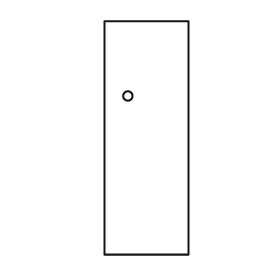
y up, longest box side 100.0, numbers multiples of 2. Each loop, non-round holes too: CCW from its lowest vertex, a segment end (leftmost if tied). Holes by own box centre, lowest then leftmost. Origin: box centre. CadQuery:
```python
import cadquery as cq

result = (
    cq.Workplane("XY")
    .moveTo(-18.0, -50.0)
    .lineTo(18.0, -50.0)
    .lineTo(18.0, 50.0)
    .lineTo(-18.0, 50.0)
    .close()
    .moveTo(-8.0, 18.0)
    .circle(2.0)
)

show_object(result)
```